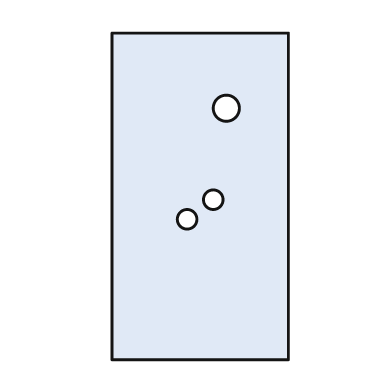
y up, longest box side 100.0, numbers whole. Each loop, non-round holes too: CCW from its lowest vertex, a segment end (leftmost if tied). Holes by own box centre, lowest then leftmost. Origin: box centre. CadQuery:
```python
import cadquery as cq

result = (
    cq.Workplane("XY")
    .moveTo(-27.0, -50.0)
    .lineTo(27.0, -50.0)
    .lineTo(27.0, 50.0)
    .lineTo(-27.0, 50.0)
    .close()
    .moveTo(-4.0, -7.0)
    .circle(3.0)
    .moveTo(4.0, -1.0)
    .circle(3.0)
    .moveTo(8.0, 27.0)
    .circle(4.0)
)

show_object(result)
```